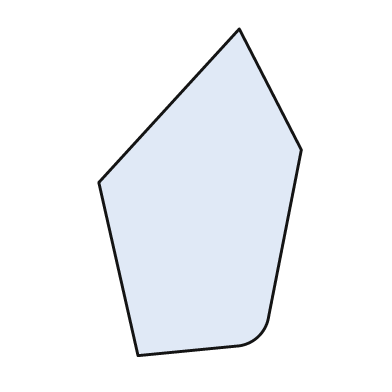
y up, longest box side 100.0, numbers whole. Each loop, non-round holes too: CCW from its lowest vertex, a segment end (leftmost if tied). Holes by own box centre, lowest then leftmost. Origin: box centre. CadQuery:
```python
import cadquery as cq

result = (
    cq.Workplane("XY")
    .moveTo(-19.0, -50.0)
    .lineTo(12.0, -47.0)
    .threePointArc((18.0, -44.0), (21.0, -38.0))
    .lineTo(31.0, 13.0)
    .lineTo(12.0, 50.0)
    .lineTo(-31.0, 3.0)
    .close()
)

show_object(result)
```